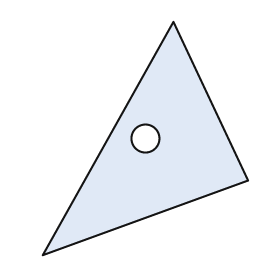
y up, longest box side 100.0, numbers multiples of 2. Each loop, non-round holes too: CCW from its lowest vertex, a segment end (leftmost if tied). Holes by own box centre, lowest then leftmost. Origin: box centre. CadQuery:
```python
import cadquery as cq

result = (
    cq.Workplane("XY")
    .moveTo(-44.0, -50.0)
    .lineTo(44.0, -18.0)
    .lineTo(12.0, 50.0)
    .close()
    .moveTo(0.0, 0.0)
    .circle(6.0)
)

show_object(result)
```